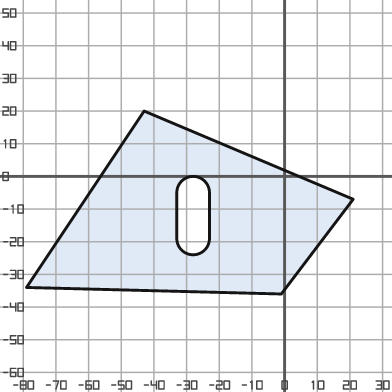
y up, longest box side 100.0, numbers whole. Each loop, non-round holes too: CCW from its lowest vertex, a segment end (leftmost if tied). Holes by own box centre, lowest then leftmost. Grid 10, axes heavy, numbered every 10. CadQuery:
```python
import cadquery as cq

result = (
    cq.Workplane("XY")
    .moveTo(-1.0, -36.0)
    .lineTo(21.0, -7.0)
    .lineTo(-43.0, 20.0)
    .lineTo(-79.0, -34.0)
    .close()
    .moveTo(-33.0, -19.0)
    .threePointArc((-28.0, -24.0), (-23.0, -19.0))
    .lineTo(-23.0, -5.0)
    .threePointArc((-28.0, 0.0), (-33.0, -5.0))
    .close()
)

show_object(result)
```